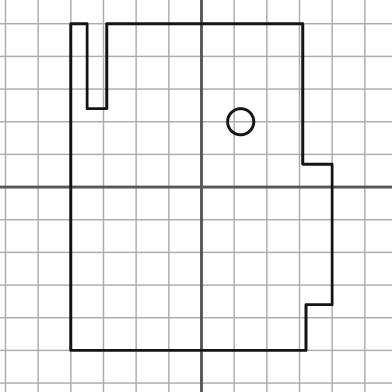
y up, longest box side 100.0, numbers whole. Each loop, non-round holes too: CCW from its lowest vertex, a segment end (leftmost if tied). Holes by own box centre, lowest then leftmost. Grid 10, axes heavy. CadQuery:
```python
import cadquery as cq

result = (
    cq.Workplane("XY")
    .moveTo(-40.0, -50.0)
    .lineTo(32.0, -50.0)
    .lineTo(32.0, -36.0)
    .lineTo(40.0, -36.0)
    .lineTo(40.0, 7.0)
    .lineTo(31.0, 7.0)
    .lineTo(31.0, 50.0)
    .lineTo(-29.0, 50.0)
    .lineTo(-29.0, 24.0)
    .lineTo(-35.0, 24.0)
    .lineTo(-35.0, 50.0)
    .lineTo(-40.0, 50.0)
    .close()
    .moveTo(12.0, 20.0)
    .circle(4.0)
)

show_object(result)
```